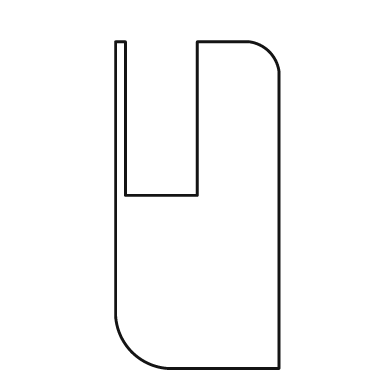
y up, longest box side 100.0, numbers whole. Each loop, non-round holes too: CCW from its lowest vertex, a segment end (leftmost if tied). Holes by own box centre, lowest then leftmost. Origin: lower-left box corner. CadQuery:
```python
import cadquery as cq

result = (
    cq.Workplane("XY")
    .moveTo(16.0, 0.0)
    .lineTo(50.0, 0.0)
    .lineTo(50.0, 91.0)
    .threePointArc((47.0, 97.0), (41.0, 100.0))
    .lineTo(25.0, 100.0)
    .lineTo(25.0, 53.0)
    .lineTo(3.0, 53.0)
    .lineTo(3.0, 100.0)
    .lineTo(0.0, 100.0)
    .lineTo(0.0, 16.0)
    .threePointArc((5.0, 5.0), (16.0, 0.0))
    .close()
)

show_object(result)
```